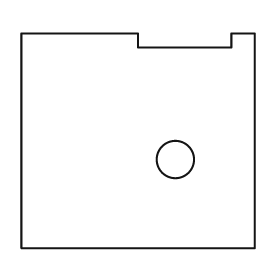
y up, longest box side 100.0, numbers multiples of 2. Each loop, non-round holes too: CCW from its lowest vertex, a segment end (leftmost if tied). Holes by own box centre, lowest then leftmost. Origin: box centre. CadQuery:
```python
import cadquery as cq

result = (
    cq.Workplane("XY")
    .moveTo(-50.0, -46.0)
    .lineTo(50.0, -46.0)
    .lineTo(50.0, 46.0)
    .lineTo(40.0, 46.0)
    .lineTo(40.0, 40.0)
    .lineTo(0.0, 40.0)
    .lineTo(0.0, 46.0)
    .lineTo(-50.0, 46.0)
    .close()
    .moveTo(16.0, -8.0)
    .circle(8.0)
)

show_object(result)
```